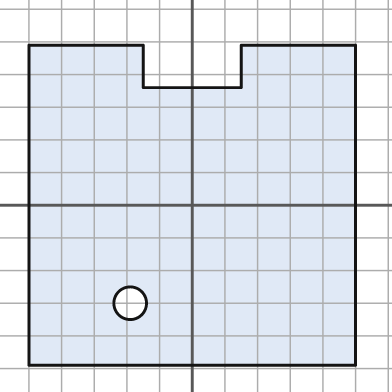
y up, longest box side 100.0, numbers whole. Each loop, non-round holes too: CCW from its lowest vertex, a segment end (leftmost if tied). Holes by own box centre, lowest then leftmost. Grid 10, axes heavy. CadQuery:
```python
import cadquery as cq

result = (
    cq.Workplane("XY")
    .moveTo(-50.0, -49.0)
    .lineTo(50.0, -49.0)
    .lineTo(50.0, 49.0)
    .lineTo(15.0, 49.0)
    .lineTo(15.0, 36.0)
    .lineTo(-15.0, 36.0)
    .lineTo(-15.0, 49.0)
    .lineTo(-50.0, 49.0)
    .close()
    .moveTo(-19.0, -30.0)
    .circle(5.0)
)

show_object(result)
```